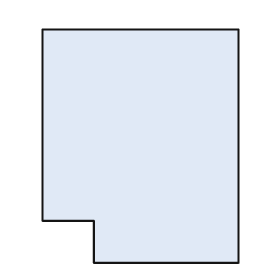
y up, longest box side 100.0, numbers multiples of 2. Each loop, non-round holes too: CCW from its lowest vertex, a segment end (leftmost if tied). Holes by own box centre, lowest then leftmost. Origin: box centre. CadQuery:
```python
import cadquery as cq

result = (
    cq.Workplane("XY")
    .moveTo(-20.0, -50.0)
    .lineTo(42.0, -50.0)
    .lineTo(42.0, 50.0)
    .lineTo(-42.0, 50.0)
    .lineTo(-42.0, -32.0)
    .lineTo(-20.0, -32.0)
    .close()
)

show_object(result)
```